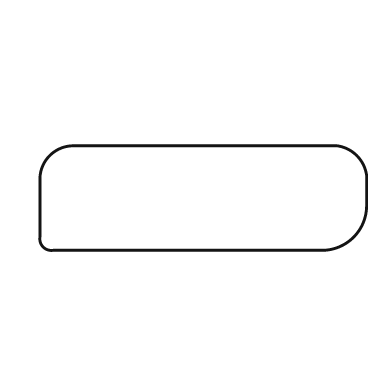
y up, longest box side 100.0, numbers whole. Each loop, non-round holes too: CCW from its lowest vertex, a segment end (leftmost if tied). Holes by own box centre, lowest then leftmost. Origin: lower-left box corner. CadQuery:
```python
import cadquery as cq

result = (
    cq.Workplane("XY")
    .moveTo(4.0, 0.0)
    .lineTo(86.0, 0.0)
    .threePointArc((96.0, 4.0), (100.0, 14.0))
    .lineTo(100.0, 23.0)
    .threePointArc((97.0, 29.0), (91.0, 32.0))
    .lineTo(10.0, 32.0)
    .threePointArc((3.0, 29.0), (0.0, 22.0))
    .lineTo(0.0, 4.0)
    .threePointArc((1.0, 1.0), (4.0, 0.0))
    .close()
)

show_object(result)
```